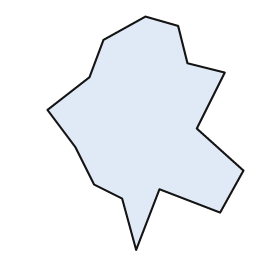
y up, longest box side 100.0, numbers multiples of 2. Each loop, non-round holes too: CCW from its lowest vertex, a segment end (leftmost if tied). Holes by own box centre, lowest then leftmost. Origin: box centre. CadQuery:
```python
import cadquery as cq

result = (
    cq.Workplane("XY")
    .moveTo(-4.0, -50.0)
    .lineTo(6.0, -24.0)
    .lineTo(32.0, -34.0)
    .lineTo(42.0, -16.0)
    .lineTo(22.0, 2.0)
    .lineTo(34.0, 26.0)
    .lineTo(18.0, 30.0)
    .lineTo(14.0, 46.0)
    .lineTo(0.0, 50.0)
    .lineTo(-18.0, 40.0)
    .lineTo(-24.0, 24.0)
    .lineTo(-42.0, 10.0)
    .lineTo(-30.0, -6.0)
    .lineTo(-22.0, -22.0)
    .lineTo(-10.0, -28.0)
    .close()
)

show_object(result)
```